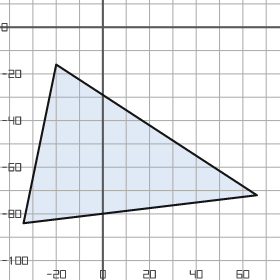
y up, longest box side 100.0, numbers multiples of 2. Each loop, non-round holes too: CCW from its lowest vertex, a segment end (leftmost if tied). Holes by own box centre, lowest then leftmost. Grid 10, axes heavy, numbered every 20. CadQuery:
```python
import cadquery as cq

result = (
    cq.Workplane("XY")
    .moveTo(-34.0, -84.0)
    .lineTo(66.0, -72.0)
    .lineTo(-20.0, -16.0)
    .close()
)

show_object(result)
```